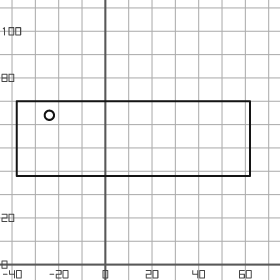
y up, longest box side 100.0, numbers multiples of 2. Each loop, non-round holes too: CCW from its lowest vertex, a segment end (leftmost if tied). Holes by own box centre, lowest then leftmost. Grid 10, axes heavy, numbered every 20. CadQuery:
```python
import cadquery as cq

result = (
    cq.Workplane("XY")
    .moveTo(-38.0, 38.0)
    .lineTo(62.0, 38.0)
    .lineTo(62.0, 70.0)
    .lineTo(-38.0, 70.0)
    .close()
    .moveTo(-24.0, 64.0)
    .circle(2.0)
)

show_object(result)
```